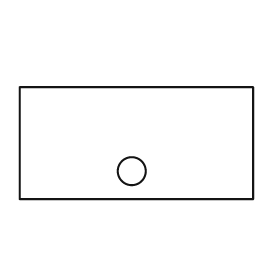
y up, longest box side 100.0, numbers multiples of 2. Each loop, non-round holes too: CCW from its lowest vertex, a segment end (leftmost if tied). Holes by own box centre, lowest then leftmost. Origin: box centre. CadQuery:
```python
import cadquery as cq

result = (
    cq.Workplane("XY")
    .moveTo(-50.0, -24.0)
    .lineTo(50.0, -24.0)
    .lineTo(50.0, 24.0)
    .lineTo(-50.0, 24.0)
    .close()
    .moveTo(-2.0, -12.0)
    .circle(6.0)
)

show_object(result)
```